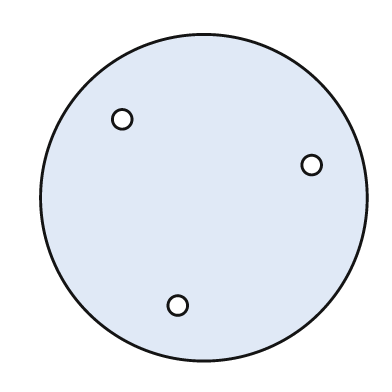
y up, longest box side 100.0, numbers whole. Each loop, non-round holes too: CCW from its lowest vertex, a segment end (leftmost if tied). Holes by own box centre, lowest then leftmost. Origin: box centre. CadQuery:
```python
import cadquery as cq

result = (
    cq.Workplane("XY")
    .moveTo(0.0, 0.0)
    .circle(50.0)
    .moveTo(-8.0, -33.0)
    .circle(3.0)
    .moveTo(33.0, 10.0)
    .circle(3.0)
    .moveTo(-25.0, 24.0)
    .circle(3.0)
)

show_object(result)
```